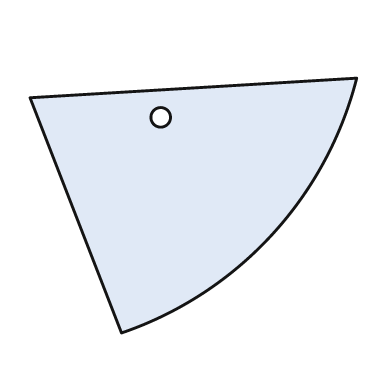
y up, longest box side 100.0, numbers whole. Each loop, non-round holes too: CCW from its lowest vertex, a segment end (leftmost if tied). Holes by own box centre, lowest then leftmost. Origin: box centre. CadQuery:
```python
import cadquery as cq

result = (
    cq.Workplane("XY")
    .moveTo(-22.0, -39.0)
    .threePointArc((24.0, -9.0), (50.0, 39.0))
    .lineTo(-50.0, 33.0)
    .close()
    .moveTo(-10.0, 27.0)
    .circle(3.0)
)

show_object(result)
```